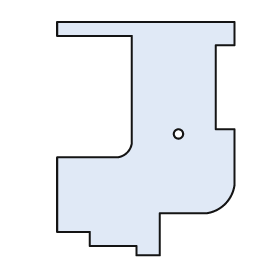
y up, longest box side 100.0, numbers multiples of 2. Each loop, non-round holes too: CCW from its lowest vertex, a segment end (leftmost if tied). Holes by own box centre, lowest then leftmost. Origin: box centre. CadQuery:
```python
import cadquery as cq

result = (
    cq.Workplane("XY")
    .moveTo(-4.0, -50.0)
    .lineTo(6.0, -50.0)
    .lineTo(6.0, -32.0)
    .lineTo(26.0, -32.0)
    .threePointArc((34.0, -28.0), (38.0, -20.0))
    .lineTo(38.0, 4.0)
    .lineTo(30.0, 4.0)
    .lineTo(30.0, 40.0)
    .lineTo(38.0, 40.0)
    .lineTo(38.0, 50.0)
    .lineTo(-38.0, 50.0)
    .lineTo(-38.0, 44.0)
    .lineTo(-6.0, 44.0)
    .lineTo(-6.0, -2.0)
    .threePointArc((-8.0, -6.0), (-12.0, -8.0))
    .lineTo(-38.0, -8.0)
    .lineTo(-38.0, -40.0)
    .lineTo(-24.0, -40.0)
    .lineTo(-24.0, -46.0)
    .lineTo(-4.0, -46.0)
    .close()
    .moveTo(14.0, 2.0)
    .circle(2.0)
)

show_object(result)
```